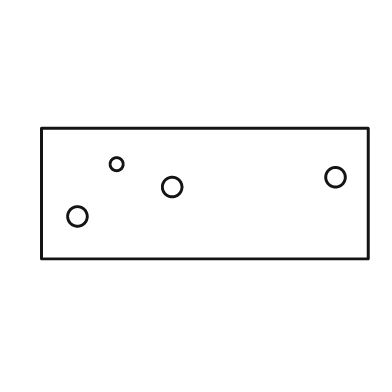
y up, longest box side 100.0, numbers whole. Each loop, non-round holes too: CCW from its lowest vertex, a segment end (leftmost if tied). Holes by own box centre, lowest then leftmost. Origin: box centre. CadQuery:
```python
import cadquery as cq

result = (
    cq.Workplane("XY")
    .moveTo(-50.0, -20.0)
    .lineTo(50.0, -20.0)
    .lineTo(50.0, 20.0)
    .lineTo(-50.0, 20.0)
    .close()
    .moveTo(-39.0, -7.0)
    .circle(3.0)
    .moveTo(-10.0, 2.0)
    .circle(3.0)
    .moveTo(40.0, 5.0)
    .circle(3.0)
    .moveTo(-27.0, 9.0)
    .circle(2.0)
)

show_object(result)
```